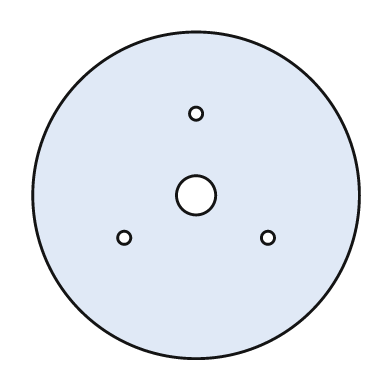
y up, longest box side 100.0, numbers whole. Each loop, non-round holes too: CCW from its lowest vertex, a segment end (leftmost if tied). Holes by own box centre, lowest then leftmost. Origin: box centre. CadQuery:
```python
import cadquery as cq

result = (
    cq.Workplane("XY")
    .moveTo(0.0, 0.0)
    .circle(50.0)
    .moveTo(-22.0, -13.0)
    .circle(2.0)
    .moveTo(22.0, -13.0)
    .circle(2.0)
    .moveTo(0.0, 0.0)
    .circle(6.0)
    .moveTo(0.0, 25.0)
    .circle(2.0)
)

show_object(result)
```